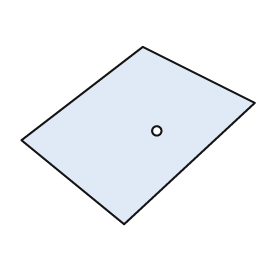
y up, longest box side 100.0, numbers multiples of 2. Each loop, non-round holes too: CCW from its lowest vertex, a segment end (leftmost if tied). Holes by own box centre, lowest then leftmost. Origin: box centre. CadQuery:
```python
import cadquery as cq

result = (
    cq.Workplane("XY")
    .moveTo(-6.0, -38.0)
    .lineTo(50.0, 14.0)
    .lineTo(2.0, 38.0)
    .lineTo(-50.0, -2.0)
    .close()
    .moveTo(8.0, 2.0)
    .circle(2.0)
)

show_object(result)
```